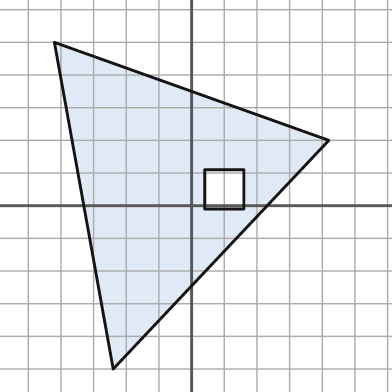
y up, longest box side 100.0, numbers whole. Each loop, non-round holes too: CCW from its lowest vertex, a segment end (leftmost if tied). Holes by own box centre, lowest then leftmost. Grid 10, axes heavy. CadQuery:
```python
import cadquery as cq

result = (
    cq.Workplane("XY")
    .moveTo(-24.0, -50.0)
    .lineTo(42.0, 20.0)
    .lineTo(-42.0, 50.0)
    .close()
    .moveTo(4.0, -1.0)
    .lineTo(16.0, -1.0)
    .lineTo(16.0, 11.0)
    .lineTo(4.0, 11.0)
    .close()
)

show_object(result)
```